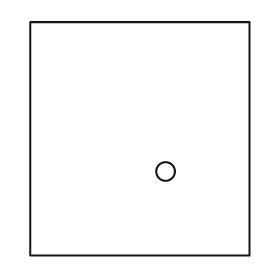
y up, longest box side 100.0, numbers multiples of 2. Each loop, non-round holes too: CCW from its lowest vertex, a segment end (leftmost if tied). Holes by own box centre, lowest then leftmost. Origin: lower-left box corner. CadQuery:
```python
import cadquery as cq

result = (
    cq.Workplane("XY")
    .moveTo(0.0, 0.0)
    .lineTo(94.0, 0.0)
    .lineTo(94.0, 100.0)
    .lineTo(0.0, 100.0)
    .close()
    .moveTo(58.0, 36.0)
    .circle(4.0)
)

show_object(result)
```